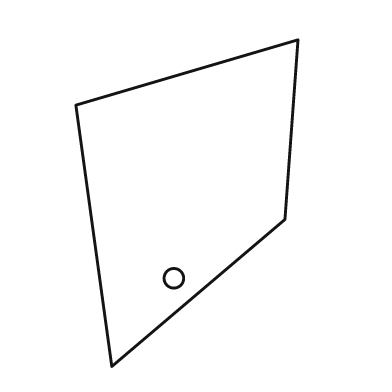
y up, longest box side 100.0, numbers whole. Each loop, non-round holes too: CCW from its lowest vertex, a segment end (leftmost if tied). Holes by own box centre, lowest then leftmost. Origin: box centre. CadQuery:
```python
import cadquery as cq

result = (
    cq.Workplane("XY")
    .moveTo(-23.0, -50.0)
    .lineTo(30.0, -5.0)
    .lineTo(34.0, 50.0)
    .lineTo(-34.0, 30.0)
    .close()
    .moveTo(-4.0, -23.0)
    .circle(3.0)
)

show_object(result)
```